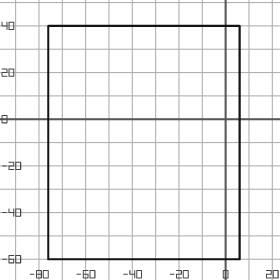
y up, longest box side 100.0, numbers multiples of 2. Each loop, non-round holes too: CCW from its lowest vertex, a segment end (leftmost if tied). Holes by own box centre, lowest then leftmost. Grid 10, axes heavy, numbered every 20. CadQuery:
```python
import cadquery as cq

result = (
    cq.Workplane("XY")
    .moveTo(-76.0, -60.0)
    .lineTo(6.0, -60.0)
    .lineTo(6.0, 40.0)
    .lineTo(-76.0, 40.0)
    .close()
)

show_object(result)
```